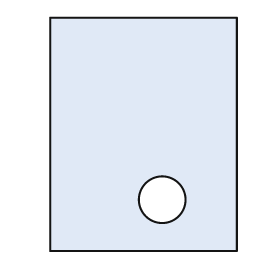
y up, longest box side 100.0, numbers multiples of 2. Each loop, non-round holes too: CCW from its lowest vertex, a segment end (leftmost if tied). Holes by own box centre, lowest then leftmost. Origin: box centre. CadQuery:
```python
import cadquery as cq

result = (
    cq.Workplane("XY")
    .moveTo(-40.0, -50.0)
    .lineTo(40.0, -50.0)
    .lineTo(40.0, 50.0)
    .lineTo(-40.0, 50.0)
    .close()
    .moveTo(8.0, -28.0)
    .circle(10.0)
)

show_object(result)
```